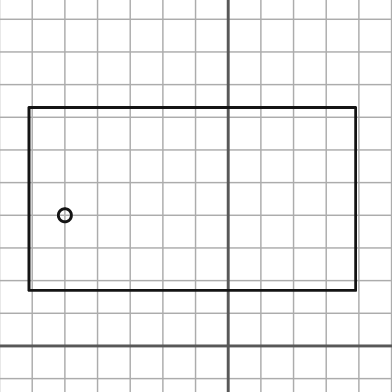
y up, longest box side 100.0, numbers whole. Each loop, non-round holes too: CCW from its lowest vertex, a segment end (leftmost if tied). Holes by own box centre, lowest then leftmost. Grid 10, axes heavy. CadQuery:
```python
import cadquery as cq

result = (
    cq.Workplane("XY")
    .moveTo(-61.0, 17.0)
    .lineTo(39.0, 17.0)
    .lineTo(39.0, 73.0)
    .lineTo(-61.0, 73.0)
    .close()
    .moveTo(-50.0, 40.0)
    .circle(2.0)
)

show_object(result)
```